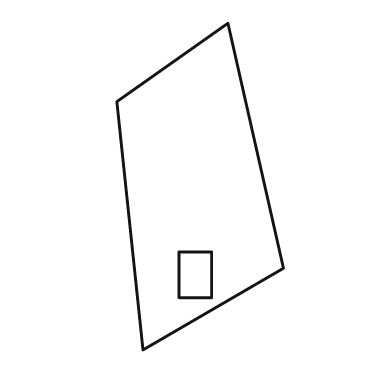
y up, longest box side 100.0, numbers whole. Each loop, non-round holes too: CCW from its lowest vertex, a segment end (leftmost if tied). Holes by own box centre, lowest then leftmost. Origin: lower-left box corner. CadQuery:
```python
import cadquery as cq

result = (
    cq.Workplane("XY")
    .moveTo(8.0, 0.0)
    .lineTo(51.0, 25.0)
    .lineTo(34.0, 100.0)
    .lineTo(0.0, 76.0)
    .close()
    .moveTo(19.0, 16.0)
    .lineTo(29.0, 16.0)
    .lineTo(29.0, 30.0)
    .lineTo(19.0, 30.0)
    .close()
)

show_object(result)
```